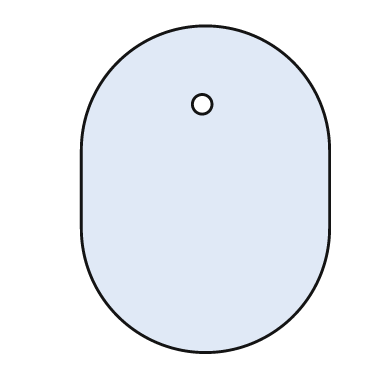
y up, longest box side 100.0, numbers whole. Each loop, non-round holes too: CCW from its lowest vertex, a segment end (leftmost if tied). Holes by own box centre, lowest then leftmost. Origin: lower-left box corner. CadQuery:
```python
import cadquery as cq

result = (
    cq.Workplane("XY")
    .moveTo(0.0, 38.0)
    .threePointArc((38.0, 0.0), (76.0, 38.0))
    .lineTo(76.0, 62.0)
    .threePointArc((38.0, 100.0), (0.0, 62.0))
    .close()
    .moveTo(37.0, 76.0)
    .circle(3.0)
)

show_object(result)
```